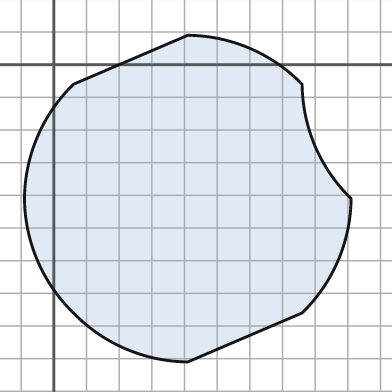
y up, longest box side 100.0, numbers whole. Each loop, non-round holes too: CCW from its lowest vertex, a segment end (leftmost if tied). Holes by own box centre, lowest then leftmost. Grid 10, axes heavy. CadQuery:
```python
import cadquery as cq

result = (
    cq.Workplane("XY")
    .moveTo(41.0, -91.0)
    .lineTo(76.0, -76.0)
    .threePointArc((87.0, -60.0), (91.0, -41.0))
    .threePointArc((80.0, -25.0), (76.0, -6.0))
    .threePointArc((60.0, 5.0), (41.0, 9.0))
    .lineTo(6.0, -6.0)
    .threePointArc((-5.0, -22.0), (-9.0, -41.0))
    .threePointArc((-5.0, -60.0), (6.0, -76.0))
    .threePointArc((22.0, -87.0), (41.0, -91.0))
    .close()
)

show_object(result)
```